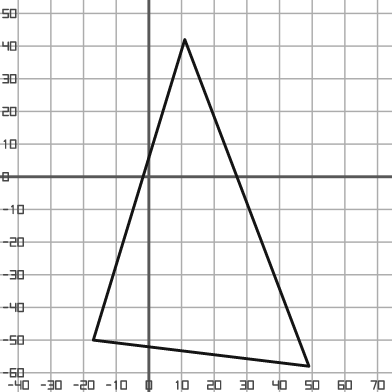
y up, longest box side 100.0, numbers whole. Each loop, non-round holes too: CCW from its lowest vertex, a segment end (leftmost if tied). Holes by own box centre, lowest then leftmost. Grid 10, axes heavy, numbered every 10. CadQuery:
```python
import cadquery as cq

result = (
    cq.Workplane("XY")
    .moveTo(49.0, -58.0)
    .lineTo(11.0, 42.0)
    .lineTo(-17.0, -50.0)
    .close()
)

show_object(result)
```